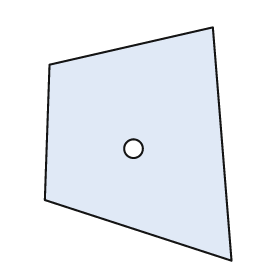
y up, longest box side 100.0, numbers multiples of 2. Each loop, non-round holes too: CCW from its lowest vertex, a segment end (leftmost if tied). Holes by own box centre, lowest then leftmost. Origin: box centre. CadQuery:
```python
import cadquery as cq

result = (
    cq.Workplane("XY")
    .moveTo(40.0, -50.0)
    .lineTo(32.0, 50.0)
    .lineTo(-38.0, 34.0)
    .lineTo(-40.0, -24.0)
    .close()
    .moveTo(-2.0, -2.0)
    .circle(4.0)
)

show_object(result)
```